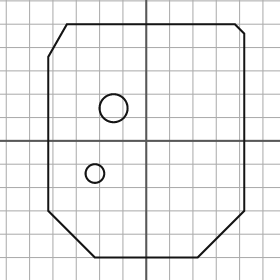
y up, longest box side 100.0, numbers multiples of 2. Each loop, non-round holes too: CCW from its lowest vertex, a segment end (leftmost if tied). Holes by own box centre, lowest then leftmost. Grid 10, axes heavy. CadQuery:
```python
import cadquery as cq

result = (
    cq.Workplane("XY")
    .moveTo(-22.0, -50.0)
    .lineTo(22.0, -50.0)
    .lineTo(42.0, -30.0)
    .lineTo(42.0, 46.0)
    .lineTo(38.0, 50.0)
    .lineTo(-34.0, 50.0)
    .lineTo(-42.0, 36.0)
    .lineTo(-42.0, -30.0)
    .close()
    .moveTo(-22.0, -14.0)
    .circle(4.0)
    .moveTo(-14.0, 14.0)
    .circle(6.0)
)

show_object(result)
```